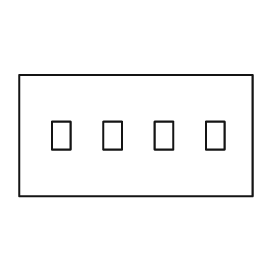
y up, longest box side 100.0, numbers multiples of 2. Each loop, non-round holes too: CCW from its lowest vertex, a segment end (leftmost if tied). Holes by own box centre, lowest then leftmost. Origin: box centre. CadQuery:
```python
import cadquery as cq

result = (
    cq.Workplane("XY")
    .moveTo(-50.0, -26.0)
    .lineTo(50.0, -26.0)
    .lineTo(50.0, 26.0)
    .lineTo(-50.0, 26.0)
    .close()
    .moveTo(-36.0, -6.0)
    .lineTo(-28.0, -6.0)
    .lineTo(-28.0, 6.0)
    .lineTo(-36.0, 6.0)
    .close()
    .moveTo(-14.0, -6.0)
    .lineTo(-6.0, -6.0)
    .lineTo(-6.0, 6.0)
    .lineTo(-14.0, 6.0)
    .close()
    .moveTo(8.0, -6.0)
    .lineTo(16.0, -6.0)
    .lineTo(16.0, 6.0)
    .lineTo(8.0, 6.0)
    .close()
    .moveTo(30.0, -6.0)
    .lineTo(38.0, -6.0)
    .lineTo(38.0, 6.0)
    .lineTo(30.0, 6.0)
    .close()
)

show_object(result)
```